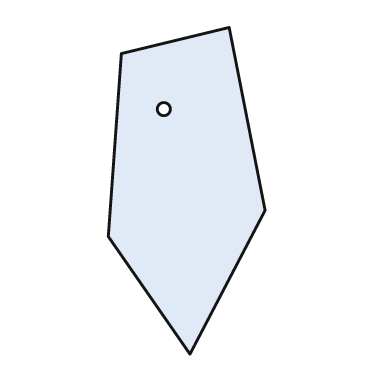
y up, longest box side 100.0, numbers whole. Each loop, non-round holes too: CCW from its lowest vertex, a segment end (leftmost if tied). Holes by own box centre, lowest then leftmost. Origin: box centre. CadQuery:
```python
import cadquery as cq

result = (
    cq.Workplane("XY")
    .moveTo(1.0, -50.0)
    .lineTo(24.0, -6.0)
    .lineTo(13.0, 50.0)
    .lineTo(-20.0, 42.0)
    .lineTo(-24.0, -14.0)
    .close()
    .moveTo(-7.0, 25.0)
    .circle(2.0)
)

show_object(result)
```